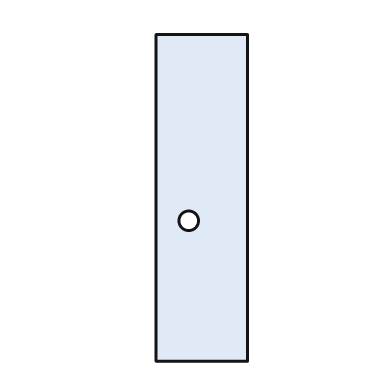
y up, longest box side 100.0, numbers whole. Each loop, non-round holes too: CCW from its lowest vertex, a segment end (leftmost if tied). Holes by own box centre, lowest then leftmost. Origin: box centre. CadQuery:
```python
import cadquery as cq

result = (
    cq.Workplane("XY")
    .moveTo(-14.0, -50.0)
    .lineTo(14.0, -50.0)
    .lineTo(14.0, 50.0)
    .lineTo(-14.0, 50.0)
    .close()
    .moveTo(-4.0, -7.0)
    .circle(3.0)
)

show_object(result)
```